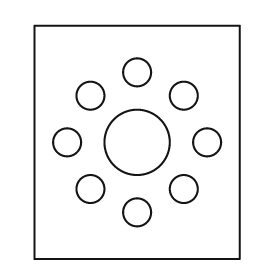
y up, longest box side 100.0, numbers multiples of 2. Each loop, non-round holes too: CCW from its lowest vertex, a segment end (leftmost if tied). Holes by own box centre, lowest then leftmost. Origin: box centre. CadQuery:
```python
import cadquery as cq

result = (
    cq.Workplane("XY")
    .moveTo(-44.0, -50.0)
    .lineTo(44.0, -50.0)
    .lineTo(44.0, 50.0)
    .lineTo(-44.0, 50.0)
    .close()
    .moveTo(0.0, -30.0)
    .circle(6.0)
    .moveTo(-20.0, -20.0)
    .circle(6.0)
    .moveTo(20.0, -20.0)
    .circle(6.0)
    .moveTo(-30.0, 0.0)
    .circle(6.0)
    .moveTo(0.0, 0.0)
    .circle(14.0)
    .moveTo(30.0, 0.0)
    .circle(6.0)
    .moveTo(-20.0, 20.0)
    .circle(6.0)
    .moveTo(20.0, 20.0)
    .circle(6.0)
    .moveTo(0.0, 30.0)
    .circle(6.0)
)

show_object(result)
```